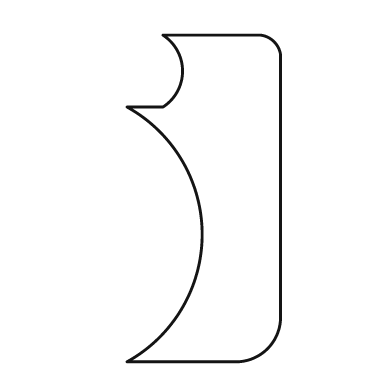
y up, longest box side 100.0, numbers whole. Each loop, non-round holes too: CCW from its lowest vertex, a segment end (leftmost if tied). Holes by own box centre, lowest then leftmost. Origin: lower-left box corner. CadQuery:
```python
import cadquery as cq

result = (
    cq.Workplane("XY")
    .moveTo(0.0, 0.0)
    .lineTo(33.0, 0.0)
    .threePointArc((43.0, 4.0), (47.0, 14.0))
    .lineTo(47.0, 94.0)
    .threePointArc((45.0, 98.0), (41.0, 100.0))
    .lineTo(11.0, 100.0)
    .threePointArc((17.0, 89.0), (11.0, 78.0))
    .lineTo(0.0, 78.0)
    .threePointArc((23.0, 39.0), (0.0, 0.0))
    .close()
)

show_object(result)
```